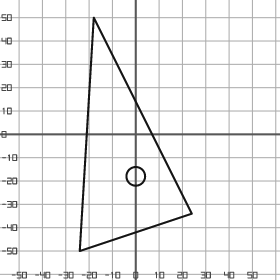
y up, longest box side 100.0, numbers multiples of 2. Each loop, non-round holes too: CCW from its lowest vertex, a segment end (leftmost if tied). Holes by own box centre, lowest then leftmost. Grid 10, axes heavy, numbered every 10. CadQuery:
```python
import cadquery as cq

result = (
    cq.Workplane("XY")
    .moveTo(-24.0, -50.0)
    .lineTo(24.0, -34.0)
    .lineTo(-18.0, 50.0)
    .close()
    .moveTo(0.0, -18.0)
    .circle(4.0)
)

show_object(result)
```